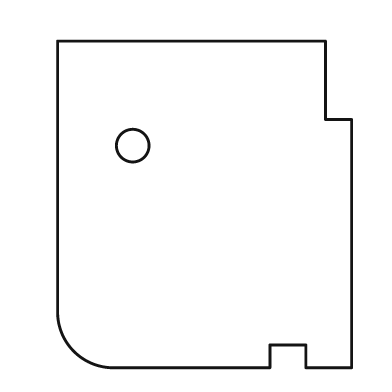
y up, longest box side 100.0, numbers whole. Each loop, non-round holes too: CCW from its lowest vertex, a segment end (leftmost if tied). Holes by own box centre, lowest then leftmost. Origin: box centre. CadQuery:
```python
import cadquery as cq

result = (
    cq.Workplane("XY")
    .moveTo(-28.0, -50.0)
    .lineTo(20.0, -50.0)
    .lineTo(20.0, -43.0)
    .lineTo(31.0, -43.0)
    .lineTo(31.0, -50.0)
    .lineTo(45.0, -50.0)
    .lineTo(45.0, 26.0)
    .lineTo(37.0, 26.0)
    .lineTo(37.0, 50.0)
    .lineTo(-45.0, 50.0)
    .lineTo(-45.0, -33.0)
    .threePointArc((-40.0, -45.0), (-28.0, -50.0))
    .close()
    .moveTo(-22.0, 18.0)
    .circle(5.0)
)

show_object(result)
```